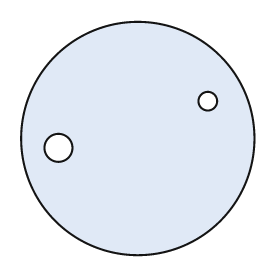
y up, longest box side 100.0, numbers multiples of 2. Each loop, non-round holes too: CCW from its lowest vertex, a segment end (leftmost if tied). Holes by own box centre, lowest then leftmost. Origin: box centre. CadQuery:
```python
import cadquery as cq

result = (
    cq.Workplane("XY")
    .moveTo(0.0, 0.0)
    .circle(50.0)
    .moveTo(-34.0, -4.0)
    .circle(6.0)
    .moveTo(30.0, 16.0)
    .circle(4.0)
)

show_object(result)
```